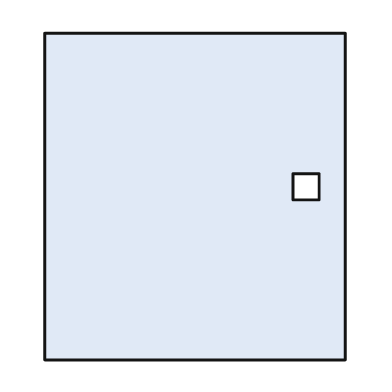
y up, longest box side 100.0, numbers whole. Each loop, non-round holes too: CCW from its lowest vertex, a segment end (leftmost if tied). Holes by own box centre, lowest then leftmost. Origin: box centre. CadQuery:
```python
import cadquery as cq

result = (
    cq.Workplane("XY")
    .moveTo(-46.0, -50.0)
    .lineTo(46.0, -50.0)
    .lineTo(46.0, 50.0)
    .lineTo(-46.0, 50.0)
    .close()
    .moveTo(30.0, -1.0)
    .lineTo(38.0, -1.0)
    .lineTo(38.0, 7.0)
    .lineTo(30.0, 7.0)
    .close()
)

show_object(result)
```